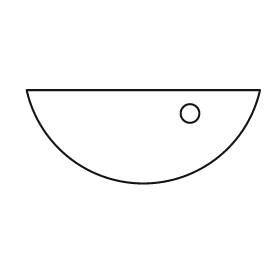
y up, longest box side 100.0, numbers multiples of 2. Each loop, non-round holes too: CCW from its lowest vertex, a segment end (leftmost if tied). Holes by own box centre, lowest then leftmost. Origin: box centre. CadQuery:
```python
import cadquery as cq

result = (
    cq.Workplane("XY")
    .moveTo(-50.0, 20.0)
    .threePointArc((0.0, -20.0), (50.0, 20.0))
    .close()
    .moveTo(20.0, 10.0)
    .circle(4.0)
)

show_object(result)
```